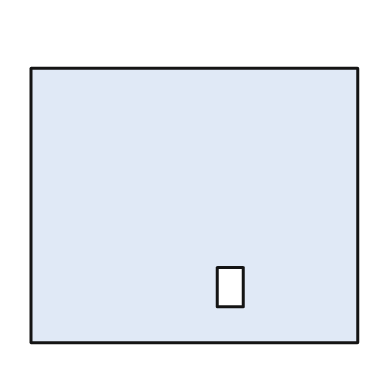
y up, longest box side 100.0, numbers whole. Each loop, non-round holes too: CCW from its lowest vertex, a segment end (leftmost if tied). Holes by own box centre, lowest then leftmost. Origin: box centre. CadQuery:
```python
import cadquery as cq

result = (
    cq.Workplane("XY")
    .moveTo(-50.0, -42.0)
    .lineTo(50.0, -42.0)
    .lineTo(50.0, 42.0)
    .lineTo(-50.0, 42.0)
    .close()
    .moveTo(7.0, -31.0)
    .lineTo(15.0, -31.0)
    .lineTo(15.0, -19.0)
    .lineTo(7.0, -19.0)
    .close()
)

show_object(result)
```